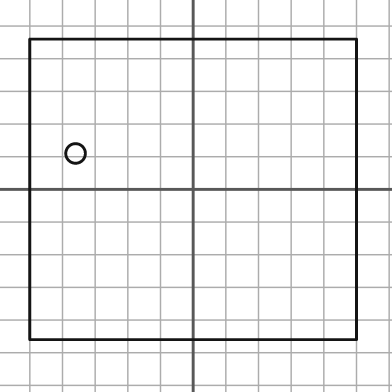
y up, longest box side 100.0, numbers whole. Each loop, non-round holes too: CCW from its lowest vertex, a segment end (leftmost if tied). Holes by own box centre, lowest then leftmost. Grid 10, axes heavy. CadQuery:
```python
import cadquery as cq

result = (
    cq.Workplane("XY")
    .moveTo(-50.0, -46.0)
    .lineTo(50.0, -46.0)
    .lineTo(50.0, 46.0)
    .lineTo(-50.0, 46.0)
    .close()
    .moveTo(-36.0, 11.0)
    .circle(3.0)
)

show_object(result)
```